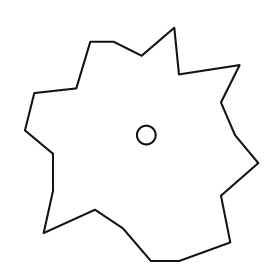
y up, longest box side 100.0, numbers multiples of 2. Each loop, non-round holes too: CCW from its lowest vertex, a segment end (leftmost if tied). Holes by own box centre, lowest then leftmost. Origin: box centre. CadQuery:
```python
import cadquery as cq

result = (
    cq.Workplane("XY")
    .moveTo(4.0, -50.0)
    .lineTo(16.0, -50.0)
    .lineTo(38.0, -42.0)
    .lineTo(34.0, -22.0)
    .lineTo(50.0, -8.0)
    .lineTo(40.0, 4.0)
    .lineTo(34.0, 18.0)
    .lineTo(42.0, 34.0)
    .lineTo(16.0, 30.0)
    .lineTo(14.0, 50.0)
    .lineTo(0.0, 38.0)
    .lineTo(-12.0, 44.0)
    .lineTo(-22.0, 44.0)
    .lineTo(-28.0, 24.0)
    .lineTo(-46.0, 22.0)
    .lineTo(-50.0, 6.0)
    .lineTo(-38.0, -4.0)
    .lineTo(-38.0, -20.0)
    .lineTo(-42.0, -38.0)
    .lineTo(-20.0, -28.0)
    .lineTo(-8.0, -36.0)
    .close()
    .moveTo(2.0, 4.0)
    .circle(4.0)
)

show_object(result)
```